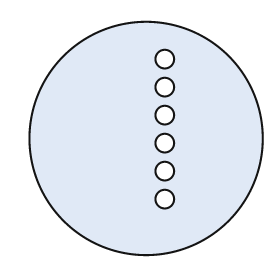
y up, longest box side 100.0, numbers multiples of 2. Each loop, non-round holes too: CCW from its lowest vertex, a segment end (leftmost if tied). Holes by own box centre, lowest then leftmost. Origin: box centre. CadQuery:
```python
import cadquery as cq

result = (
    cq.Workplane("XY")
    .moveTo(0.0, 0.0)
    .circle(50.0)
    .moveTo(8.0, -26.0)
    .circle(4.0)
    .moveTo(8.0, -14.0)
    .circle(4.0)
    .moveTo(8.0, -2.0)
    .circle(4.0)
    .moveTo(8.0, 10.0)
    .circle(4.0)
    .moveTo(8.0, 22.0)
    .circle(4.0)
    .moveTo(8.0, 34.0)
    .circle(4.0)
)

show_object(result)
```